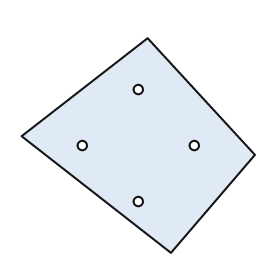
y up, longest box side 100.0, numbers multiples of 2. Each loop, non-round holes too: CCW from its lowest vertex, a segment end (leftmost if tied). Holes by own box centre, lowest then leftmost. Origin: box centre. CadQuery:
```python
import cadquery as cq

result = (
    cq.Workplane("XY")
    .moveTo(14.0, -46.0)
    .lineTo(50.0, -4.0)
    .lineTo(4.0, 46.0)
    .lineTo(-50.0, 4.0)
    .close()
    .moveTo(0.0, -24.0)
    .circle(2.0)
    .moveTo(-24.0, 0.0)
    .circle(2.0)
    .moveTo(24.0, 0.0)
    .circle(2.0)
    .moveTo(0.0, 24.0)
    .circle(2.0)
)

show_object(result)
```